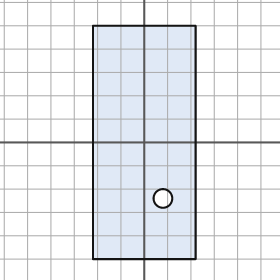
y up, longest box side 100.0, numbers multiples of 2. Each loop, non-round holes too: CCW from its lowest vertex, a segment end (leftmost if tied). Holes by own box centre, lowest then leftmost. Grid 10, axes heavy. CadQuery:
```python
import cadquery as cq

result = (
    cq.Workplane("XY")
    .moveTo(-22.0, -50.0)
    .lineTo(22.0, -50.0)
    .lineTo(22.0, 50.0)
    .lineTo(-22.0, 50.0)
    .close()
    .moveTo(8.0, -24.0)
    .circle(4.0)
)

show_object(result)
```